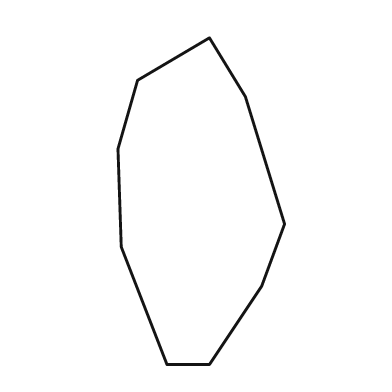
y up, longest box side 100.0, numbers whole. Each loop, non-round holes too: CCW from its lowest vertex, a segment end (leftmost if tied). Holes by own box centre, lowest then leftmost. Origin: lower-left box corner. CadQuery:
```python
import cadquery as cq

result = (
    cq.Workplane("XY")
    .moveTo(15.0, 0.0)
    .lineTo(28.0, 0.0)
    .lineTo(44.0, 24.0)
    .lineTo(51.0, 43.0)
    .lineTo(39.0, 82.0)
    .lineTo(28.0, 100.0)
    .lineTo(6.0, 87.0)
    .lineTo(0.0, 66.0)
    .lineTo(1.0, 36.0)
    .close()
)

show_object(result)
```